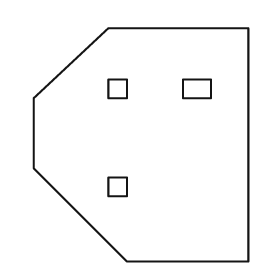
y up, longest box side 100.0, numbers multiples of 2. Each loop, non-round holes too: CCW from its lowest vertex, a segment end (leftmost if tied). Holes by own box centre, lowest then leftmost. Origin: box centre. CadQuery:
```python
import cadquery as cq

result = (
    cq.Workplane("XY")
    .moveTo(-6.0, -50.0)
    .lineTo(46.0, -50.0)
    .lineTo(46.0, 50.0)
    .lineTo(-14.0, 50.0)
    .lineTo(-46.0, 20.0)
    .lineTo(-46.0, -10.0)
    .close()
    .moveTo(-14.0, -22.0)
    .lineTo(-6.0, -22.0)
    .lineTo(-6.0, -14.0)
    .lineTo(-14.0, -14.0)
    .close()
    .moveTo(-14.0, 20.0)
    .lineTo(-6.0, 20.0)
    .lineTo(-6.0, 28.0)
    .lineTo(-14.0, 28.0)
    .close()
    .moveTo(18.0, 20.0)
    .lineTo(30.0, 20.0)
    .lineTo(30.0, 28.0)
    .lineTo(18.0, 28.0)
    .close()
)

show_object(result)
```